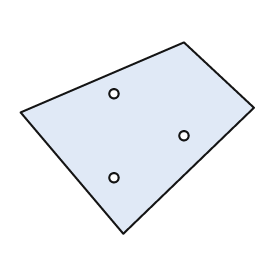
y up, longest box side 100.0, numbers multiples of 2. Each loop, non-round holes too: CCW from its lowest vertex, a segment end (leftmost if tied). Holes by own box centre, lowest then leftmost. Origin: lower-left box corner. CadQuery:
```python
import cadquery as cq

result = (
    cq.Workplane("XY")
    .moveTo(44.0, 0.0)
    .lineTo(100.0, 54.0)
    .lineTo(70.0, 82.0)
    .lineTo(0.0, 52.0)
    .close()
    .moveTo(40.0, 24.0)
    .circle(2.0)
    .moveTo(70.0, 42.0)
    .circle(2.0)
    .moveTo(40.0, 60.0)
    .circle(2.0)
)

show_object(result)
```